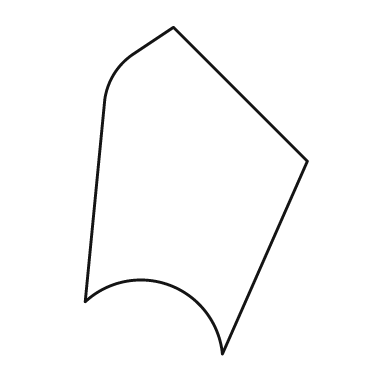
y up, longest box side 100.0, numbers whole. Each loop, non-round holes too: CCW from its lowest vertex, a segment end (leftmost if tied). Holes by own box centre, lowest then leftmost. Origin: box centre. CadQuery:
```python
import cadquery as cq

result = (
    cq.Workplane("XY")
    .moveTo(8.0, -50.0)
    .lineTo(34.0, 9.0)
    .lineTo(-7.0, 50.0)
    .lineTo(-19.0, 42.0)
    .threePointArc((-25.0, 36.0), (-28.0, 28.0))
    .lineTo(-34.0, -34.0)
    .threePointArc((-8.0, -29.0), (8.0, -50.0))
    .close()
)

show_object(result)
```